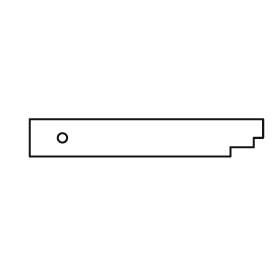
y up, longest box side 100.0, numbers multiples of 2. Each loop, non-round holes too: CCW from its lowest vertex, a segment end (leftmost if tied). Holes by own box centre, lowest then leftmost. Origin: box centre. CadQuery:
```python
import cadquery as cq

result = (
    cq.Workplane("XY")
    .moveTo(-50.0, -8.0)
    .lineTo(36.0, -8.0)
    .lineTo(36.0, -4.0)
    .lineTo(46.0, -4.0)
    .lineTo(46.0, 0.0)
    .lineTo(50.0, 0.0)
    .lineTo(50.0, 8.0)
    .lineTo(-50.0, 8.0)
    .close()
    .moveTo(-36.0, 0.0)
    .circle(2.0)
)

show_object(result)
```